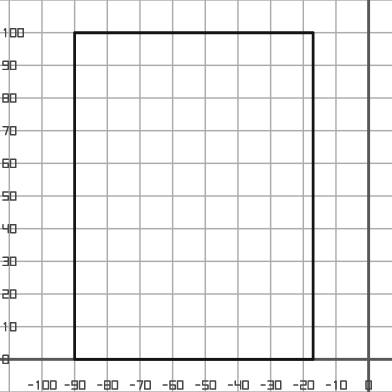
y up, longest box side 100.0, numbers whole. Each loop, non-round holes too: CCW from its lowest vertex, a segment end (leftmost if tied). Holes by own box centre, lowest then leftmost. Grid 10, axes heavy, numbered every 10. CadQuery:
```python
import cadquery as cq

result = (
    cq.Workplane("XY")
    .moveTo(-90.0, 0.0)
    .lineTo(-17.0, 0.0)
    .lineTo(-17.0, 100.0)
    .lineTo(-90.0, 100.0)
    .close()
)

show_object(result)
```